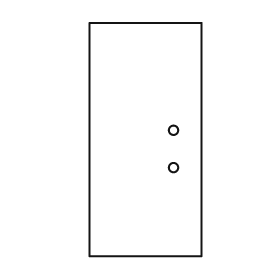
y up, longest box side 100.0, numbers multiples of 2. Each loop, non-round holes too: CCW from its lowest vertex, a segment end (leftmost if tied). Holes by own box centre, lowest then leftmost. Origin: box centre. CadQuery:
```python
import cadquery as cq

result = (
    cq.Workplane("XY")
    .moveTo(-24.0, -50.0)
    .lineTo(24.0, -50.0)
    .lineTo(24.0, 50.0)
    .lineTo(-24.0, 50.0)
    .close()
    .moveTo(12.0, -12.0)
    .circle(2.0)
    .moveTo(12.0, 4.0)
    .circle(2.0)
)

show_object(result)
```